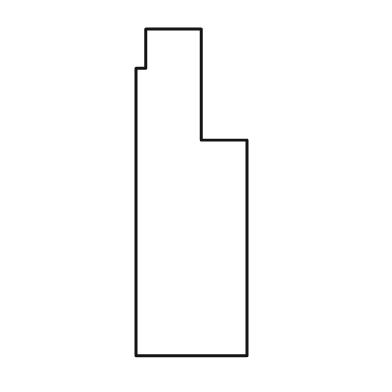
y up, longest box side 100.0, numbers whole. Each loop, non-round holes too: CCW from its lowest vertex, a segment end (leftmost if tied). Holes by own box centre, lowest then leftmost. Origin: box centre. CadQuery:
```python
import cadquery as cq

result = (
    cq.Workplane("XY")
    .moveTo(-17.0, -50.0)
    .lineTo(17.0, -50.0)
    .lineTo(17.0, 16.0)
    .lineTo(3.0, 16.0)
    .lineTo(3.0, 50.0)
    .lineTo(-14.0, 50.0)
    .lineTo(-14.0, 38.0)
    .lineTo(-17.0, 38.0)
    .close()
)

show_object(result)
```